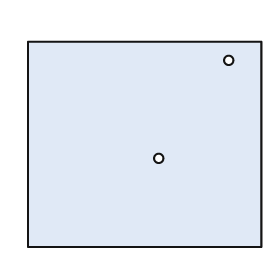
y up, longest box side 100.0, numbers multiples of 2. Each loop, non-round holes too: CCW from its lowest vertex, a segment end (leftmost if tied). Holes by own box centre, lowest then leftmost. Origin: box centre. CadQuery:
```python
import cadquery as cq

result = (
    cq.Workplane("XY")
    .moveTo(-50.0, -44.0)
    .lineTo(50.0, -44.0)
    .lineTo(50.0, 44.0)
    .lineTo(-50.0, 44.0)
    .close()
    .moveTo(6.0, -6.0)
    .circle(2.0)
    .moveTo(36.0, 36.0)
    .circle(2.0)
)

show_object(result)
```